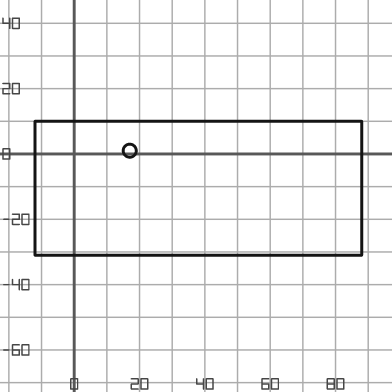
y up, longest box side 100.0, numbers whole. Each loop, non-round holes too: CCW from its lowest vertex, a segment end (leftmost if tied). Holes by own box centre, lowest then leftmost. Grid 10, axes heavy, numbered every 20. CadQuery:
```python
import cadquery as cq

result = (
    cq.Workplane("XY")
    .moveTo(-12.0, -31.0)
    .lineTo(88.0, -31.0)
    .lineTo(88.0, 10.0)
    .lineTo(-12.0, 10.0)
    .close()
    .moveTo(17.0, 1.0)
    .circle(2.0)
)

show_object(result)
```